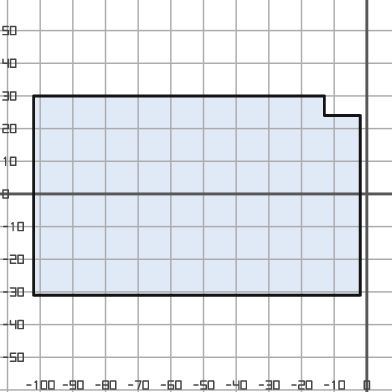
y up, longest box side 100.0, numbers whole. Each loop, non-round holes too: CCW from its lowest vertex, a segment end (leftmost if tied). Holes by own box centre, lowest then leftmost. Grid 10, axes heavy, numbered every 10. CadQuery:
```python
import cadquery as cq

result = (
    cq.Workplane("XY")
    .moveTo(-102.0, -31.0)
    .lineTo(-2.0, -31.0)
    .lineTo(-2.0, 24.0)
    .lineTo(-13.0, 24.0)
    .lineTo(-13.0, 30.0)
    .lineTo(-102.0, 30.0)
    .close()
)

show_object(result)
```